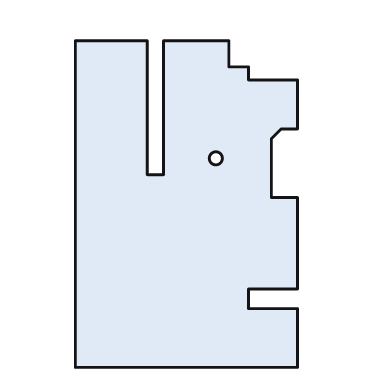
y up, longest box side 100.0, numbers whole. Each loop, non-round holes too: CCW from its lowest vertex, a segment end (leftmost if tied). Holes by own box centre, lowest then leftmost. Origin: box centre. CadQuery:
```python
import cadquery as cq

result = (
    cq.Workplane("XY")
    .moveTo(-34.0, -50.0)
    .lineTo(34.0, -50.0)
    .lineTo(34.0, -32.0)
    .lineTo(19.0, -32.0)
    .lineTo(19.0, -26.0)
    .lineTo(34.0, -26.0)
    .lineTo(34.0, 2.0)
    .lineTo(26.0, 2.0)
    .lineTo(26.0, 20.0)
    .lineTo(29.0, 23.0)
    .lineTo(34.0, 23.0)
    .lineTo(34.0, 38.0)
    .lineTo(19.0, 38.0)
    .lineTo(19.0, 42.0)
    .lineTo(13.0, 42.0)
    .lineTo(13.0, 50.0)
    .lineTo(-7.0, 50.0)
    .lineTo(-7.0, 9.0)
    .lineTo(-12.0, 9.0)
    .lineTo(-12.0, 50.0)
    .lineTo(-34.0, 50.0)
    .close()
    .moveTo(9.0, 14.0)
    .circle(2.0)
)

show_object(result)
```